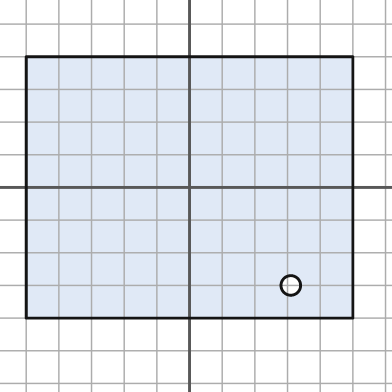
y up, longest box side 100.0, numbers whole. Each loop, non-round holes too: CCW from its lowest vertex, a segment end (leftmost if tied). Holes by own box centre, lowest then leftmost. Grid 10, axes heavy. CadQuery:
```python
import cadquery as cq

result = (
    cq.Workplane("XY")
    .moveTo(-50.0, -40.0)
    .lineTo(50.0, -40.0)
    .lineTo(50.0, 40.0)
    .lineTo(-50.0, 40.0)
    .close()
    .moveTo(31.0, -30.0)
    .circle(3.0)
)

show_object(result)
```